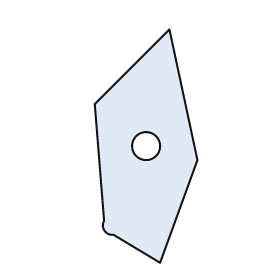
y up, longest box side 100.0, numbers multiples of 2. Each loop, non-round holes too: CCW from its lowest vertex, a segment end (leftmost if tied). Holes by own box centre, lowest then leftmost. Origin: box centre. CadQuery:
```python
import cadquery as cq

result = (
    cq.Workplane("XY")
    .moveTo(6.0, -50.0)
    .lineTo(22.0, -6.0)
    .lineTo(10.0, 50.0)
    .lineTo(-22.0, 18.0)
    .lineTo(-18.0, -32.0)
    .threePointArc((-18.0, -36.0), (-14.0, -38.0))
    .close()
    .moveTo(0.0, 0.0)
    .circle(6.0)
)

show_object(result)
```